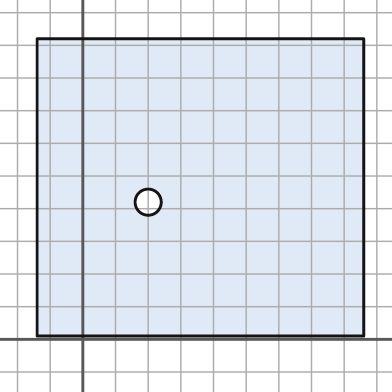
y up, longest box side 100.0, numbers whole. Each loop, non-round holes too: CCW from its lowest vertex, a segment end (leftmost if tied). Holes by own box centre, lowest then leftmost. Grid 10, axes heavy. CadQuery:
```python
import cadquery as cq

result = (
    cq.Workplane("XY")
    .moveTo(-14.0, 1.0)
    .lineTo(86.0, 1.0)
    .lineTo(86.0, 92.0)
    .lineTo(-14.0, 92.0)
    .close()
    .moveTo(20.0, 42.0)
    .circle(4.0)
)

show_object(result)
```